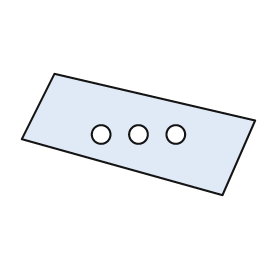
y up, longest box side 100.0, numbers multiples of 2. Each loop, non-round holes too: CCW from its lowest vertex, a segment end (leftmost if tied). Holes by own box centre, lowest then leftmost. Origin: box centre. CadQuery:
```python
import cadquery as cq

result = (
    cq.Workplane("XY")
    .moveTo(36.0, -26.0)
    .lineTo(50.0, 6.0)
    .lineTo(-36.0, 26.0)
    .lineTo(-50.0, -2.0)
    .close()
    .moveTo(-16.0, 0.0)
    .circle(4.0)
    .moveTo(0.0, 0.0)
    .circle(4.0)
    .moveTo(16.0, 0.0)
    .circle(4.0)
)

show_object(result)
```